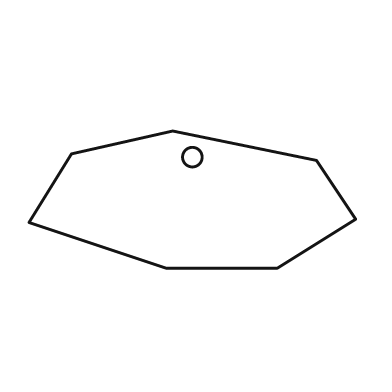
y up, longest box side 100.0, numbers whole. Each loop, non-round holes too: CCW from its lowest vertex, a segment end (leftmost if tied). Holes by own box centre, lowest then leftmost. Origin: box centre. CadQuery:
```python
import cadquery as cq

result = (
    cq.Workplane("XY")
    .moveTo(-8.0, -21.0)
    .lineTo(26.0, -21.0)
    .lineTo(50.0, -6.0)
    .lineTo(38.0, 12.0)
    .lineTo(-6.0, 21.0)
    .lineTo(-37.0, 14.0)
    .lineTo(-50.0, -7.0)
    .close()
    .moveTo(0.0, 13.0)
    .circle(3.0)
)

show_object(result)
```